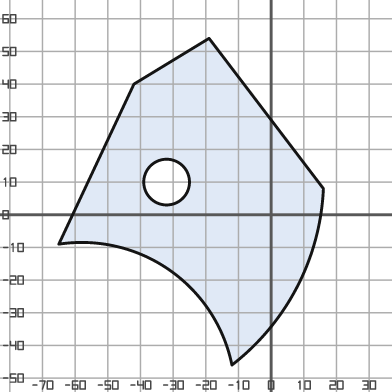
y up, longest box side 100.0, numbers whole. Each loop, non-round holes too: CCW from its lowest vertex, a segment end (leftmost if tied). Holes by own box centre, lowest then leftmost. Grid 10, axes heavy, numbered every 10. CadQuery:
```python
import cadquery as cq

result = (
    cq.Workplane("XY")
    .moveTo(-12.0, -46.0)
    .threePointArc((8.0, -22.0), (16.0, 8.0))
    .lineTo(-19.0, 54.0)
    .lineTo(-42.0, 40.0)
    .lineTo(-65.0, -9.0)
    .threePointArc((-31.0, -17.0), (-12.0, -46.0))
    .close()
    .moveTo(-32.0, 10.0)
    .circle(7.0)
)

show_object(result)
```